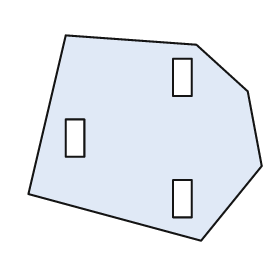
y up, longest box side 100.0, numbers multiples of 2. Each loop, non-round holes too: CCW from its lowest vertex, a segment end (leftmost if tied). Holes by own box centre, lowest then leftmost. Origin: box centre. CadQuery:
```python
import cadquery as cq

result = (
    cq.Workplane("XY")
    .moveTo(24.0, -44.0)
    .lineTo(50.0, -12.0)
    .lineTo(44.0, 20.0)
    .lineTo(22.0, 40.0)
    .lineTo(-34.0, 44.0)
    .lineTo(-50.0, -24.0)
    .close()
    .moveTo(12.0, -34.0)
    .lineTo(20.0, -34.0)
    .lineTo(20.0, -18.0)
    .lineTo(12.0, -18.0)
    .close()
    .moveTo(-34.0, -8.0)
    .lineTo(-26.0, -8.0)
    .lineTo(-26.0, 8.0)
    .lineTo(-34.0, 8.0)
    .close()
    .moveTo(12.0, 18.0)
    .lineTo(20.0, 18.0)
    .lineTo(20.0, 34.0)
    .lineTo(12.0, 34.0)
    .close()
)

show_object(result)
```